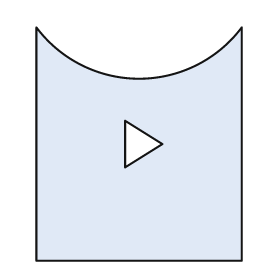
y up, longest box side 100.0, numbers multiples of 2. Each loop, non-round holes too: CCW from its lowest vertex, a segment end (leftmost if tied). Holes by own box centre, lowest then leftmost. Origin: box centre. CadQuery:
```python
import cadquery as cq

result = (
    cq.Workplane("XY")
    .moveTo(-44.0, -50.0)
    .lineTo(44.0, -50.0)
    .lineTo(44.0, 50.0)
    .threePointArc((0.0, 28.0), (-44.0, 50.0))
    .close()
    .moveTo(-6.0, -10.0)
    .lineTo(10.0, 0.0)
    .lineTo(-6.0, 10.0)
    .close()
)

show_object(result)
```